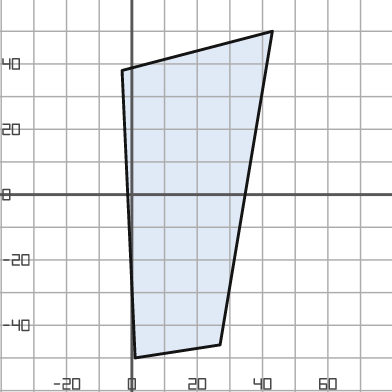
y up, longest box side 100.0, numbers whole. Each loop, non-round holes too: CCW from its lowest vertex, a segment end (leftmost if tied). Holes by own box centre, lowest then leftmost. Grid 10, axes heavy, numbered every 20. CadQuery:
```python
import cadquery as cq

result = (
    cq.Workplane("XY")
    .moveTo(1.0, -50.0)
    .lineTo(27.0, -46.0)
    .lineTo(43.0, 50.0)
    .lineTo(-3.0, 38.0)
    .close()
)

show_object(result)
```